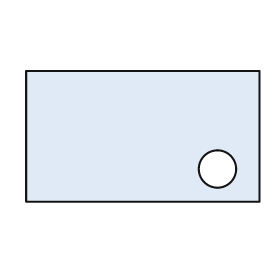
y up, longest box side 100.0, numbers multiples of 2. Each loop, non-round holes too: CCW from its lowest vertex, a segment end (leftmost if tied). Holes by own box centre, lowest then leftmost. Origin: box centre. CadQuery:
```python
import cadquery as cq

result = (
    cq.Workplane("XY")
    .moveTo(-50.0, -28.0)
    .lineTo(50.0, -28.0)
    .lineTo(50.0, 28.0)
    .lineTo(-50.0, 28.0)
    .close()
    .moveTo(32.0, -14.0)
    .circle(8.0)
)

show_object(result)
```